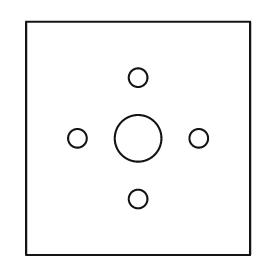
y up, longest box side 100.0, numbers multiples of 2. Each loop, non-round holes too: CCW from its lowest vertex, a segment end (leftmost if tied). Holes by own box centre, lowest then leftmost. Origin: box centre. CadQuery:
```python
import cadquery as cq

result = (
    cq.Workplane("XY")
    .moveTo(-48.0, -50.0)
    .lineTo(48.0, -50.0)
    .lineTo(48.0, 50.0)
    .lineTo(-48.0, 50.0)
    .close()
    .moveTo(0.0, -26.0)
    .circle(4.0)
    .moveTo(-26.0, 0.0)
    .circle(4.0)
    .moveTo(0.0, 0.0)
    .circle(10.0)
    .moveTo(26.0, 0.0)
    .circle(4.0)
    .moveTo(0.0, 26.0)
    .circle(4.0)
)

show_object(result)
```